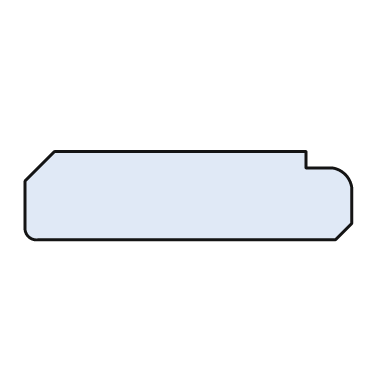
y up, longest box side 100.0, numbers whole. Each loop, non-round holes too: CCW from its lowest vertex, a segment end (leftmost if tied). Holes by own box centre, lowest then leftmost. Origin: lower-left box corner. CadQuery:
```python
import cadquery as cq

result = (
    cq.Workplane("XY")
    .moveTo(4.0, 0.0)
    .lineTo(95.0, 0.0)
    .lineTo(100.0, 5.0)
    .lineTo(100.0, 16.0)
    .threePointArc((98.0, 20.0), (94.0, 22.0))
    .lineTo(86.0, 22.0)
    .lineTo(86.0, 27.0)
    .lineTo(9.0, 27.0)
    .lineTo(0.0, 18.0)
    .lineTo(0.0, 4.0)
    .threePointArc((1.0, 1.0), (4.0, 0.0))
    .close()
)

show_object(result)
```